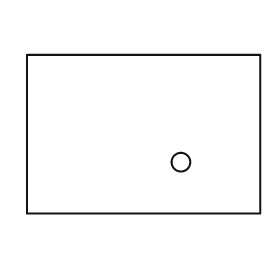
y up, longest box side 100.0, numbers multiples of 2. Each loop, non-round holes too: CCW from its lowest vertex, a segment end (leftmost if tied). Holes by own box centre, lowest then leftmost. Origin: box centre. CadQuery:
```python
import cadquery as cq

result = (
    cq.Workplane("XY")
    .moveTo(-50.0, -34.0)
    .lineTo(50.0, -34.0)
    .lineTo(50.0, 34.0)
    .lineTo(-50.0, 34.0)
    .close()
    .moveTo(16.0, -12.0)
    .circle(4.0)
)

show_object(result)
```